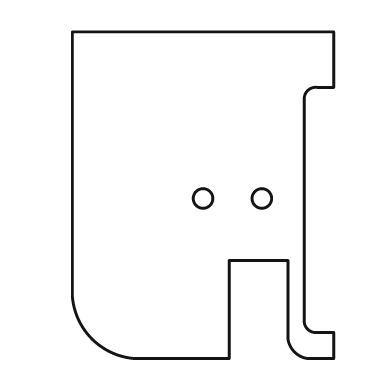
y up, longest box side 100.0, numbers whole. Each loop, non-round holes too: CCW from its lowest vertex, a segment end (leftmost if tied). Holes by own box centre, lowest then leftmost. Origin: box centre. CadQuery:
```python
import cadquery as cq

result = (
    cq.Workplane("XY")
    .moveTo(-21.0, -50.0)
    .lineTo(8.0, -50.0)
    .lineTo(8.0, -20.0)
    .lineTo(26.0, -20.0)
    .lineTo(26.0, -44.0)
    .threePointArc((28.0, -48.0), (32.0, -50.0))
    .lineTo(40.0, -50.0)
    .lineTo(40.0, -42.0)
    .lineTo(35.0, -42.0)
    .threePointArc((32.0, -41.0), (31.0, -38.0))
    .lineTo(31.0, 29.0)
    .threePointArc((32.0, 32.0), (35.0, 33.0))
    .lineTo(40.0, 33.0)
    .lineTo(40.0, 50.0)
    .lineTo(-40.0, 50.0)
    .lineTo(-40.0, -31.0)
    .threePointArc((-34.0, -44.0), (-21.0, -50.0))
    .close()
    .moveTo(0.0, -1.0)
    .circle(3.0)
    .moveTo(18.0, -1.0)
    .circle(3.0)
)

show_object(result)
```